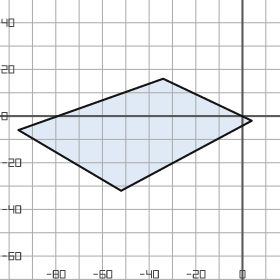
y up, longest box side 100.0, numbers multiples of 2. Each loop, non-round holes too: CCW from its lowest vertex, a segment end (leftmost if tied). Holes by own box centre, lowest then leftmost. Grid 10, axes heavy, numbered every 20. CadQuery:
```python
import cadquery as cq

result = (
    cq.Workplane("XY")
    .moveTo(-52.0, -32.0)
    .lineTo(4.0, -2.0)
    .lineTo(-34.0, 16.0)
    .lineTo(-96.0, -6.0)
    .close()
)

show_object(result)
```